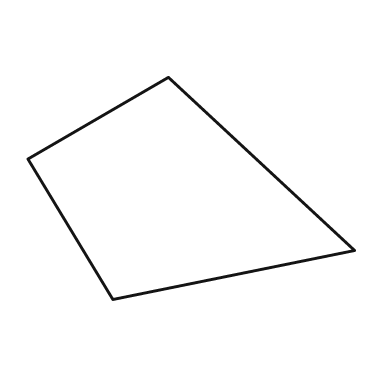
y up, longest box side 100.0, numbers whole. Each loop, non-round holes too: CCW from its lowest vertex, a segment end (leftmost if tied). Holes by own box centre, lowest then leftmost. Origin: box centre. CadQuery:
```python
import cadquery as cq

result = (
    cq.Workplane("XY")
    .moveTo(-24.0, -34.0)
    .lineTo(50.0, -19.0)
    .lineTo(-7.0, 34.0)
    .lineTo(-50.0, 9.0)
    .close()
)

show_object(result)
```